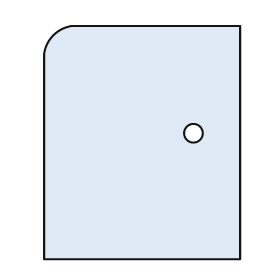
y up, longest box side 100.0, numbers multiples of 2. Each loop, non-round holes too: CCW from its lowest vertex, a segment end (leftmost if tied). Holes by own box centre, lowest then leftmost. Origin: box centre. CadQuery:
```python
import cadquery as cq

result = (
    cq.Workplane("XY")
    .moveTo(-42.0, -50.0)
    .lineTo(42.0, -50.0)
    .lineTo(42.0, 50.0)
    .lineTo(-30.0, 50.0)
    .threePointArc((-38.0, 46.0), (-42.0, 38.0))
    .close()
    .moveTo(22.0, 4.0)
    .circle(4.0)
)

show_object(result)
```